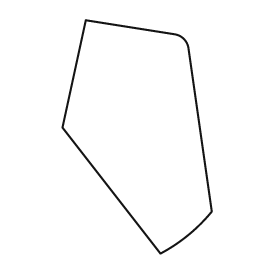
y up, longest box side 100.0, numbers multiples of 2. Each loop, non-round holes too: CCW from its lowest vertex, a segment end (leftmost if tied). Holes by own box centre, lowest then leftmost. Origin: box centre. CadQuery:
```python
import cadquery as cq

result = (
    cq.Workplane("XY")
    .moveTo(10.0, -50.0)
    .threePointArc((22.0, -42.0), (32.0, -32.0))
    .lineTo(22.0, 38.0)
    .threePointArc((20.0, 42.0), (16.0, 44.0))
    .lineTo(-22.0, 50.0)
    .lineTo(-32.0, 4.0)
    .close()
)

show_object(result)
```